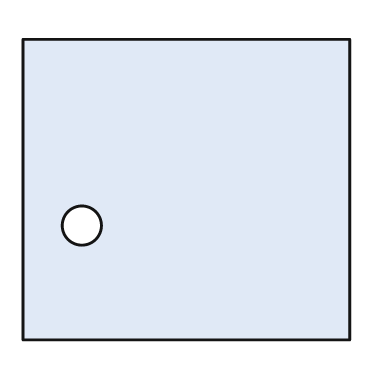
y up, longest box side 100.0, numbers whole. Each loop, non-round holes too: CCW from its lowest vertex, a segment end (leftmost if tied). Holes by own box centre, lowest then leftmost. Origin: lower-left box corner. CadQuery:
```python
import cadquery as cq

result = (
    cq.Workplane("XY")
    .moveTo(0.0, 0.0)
    .lineTo(100.0, 0.0)
    .lineTo(100.0, 92.0)
    .lineTo(0.0, 92.0)
    .close()
    .moveTo(18.0, 35.0)
    .circle(6.0)
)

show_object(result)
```